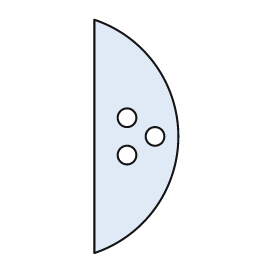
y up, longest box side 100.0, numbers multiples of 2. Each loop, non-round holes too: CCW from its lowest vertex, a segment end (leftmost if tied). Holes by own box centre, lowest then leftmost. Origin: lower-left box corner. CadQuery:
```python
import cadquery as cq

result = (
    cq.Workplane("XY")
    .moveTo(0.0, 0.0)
    .threePointArc((36.0, 50.0), (0.0, 100.0))
    .close()
    .moveTo(14.0, 42.0)
    .circle(4.0)
    .moveTo(26.0, 50.0)
    .circle(4.0)
    .moveTo(14.0, 58.0)
    .circle(4.0)
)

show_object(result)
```